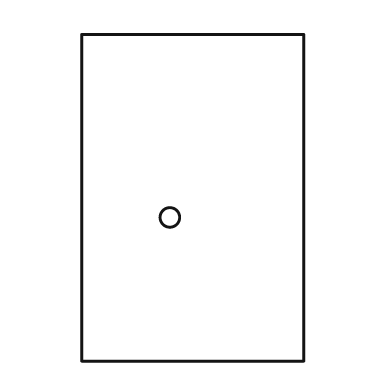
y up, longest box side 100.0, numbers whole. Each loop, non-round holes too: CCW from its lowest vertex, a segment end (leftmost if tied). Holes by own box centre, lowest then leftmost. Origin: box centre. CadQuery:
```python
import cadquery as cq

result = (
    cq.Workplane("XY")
    .moveTo(-34.0, -50.0)
    .lineTo(34.0, -50.0)
    .lineTo(34.0, 50.0)
    .lineTo(-34.0, 50.0)
    .close()
    .moveTo(-7.0, -6.0)
    .circle(3.0)
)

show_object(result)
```